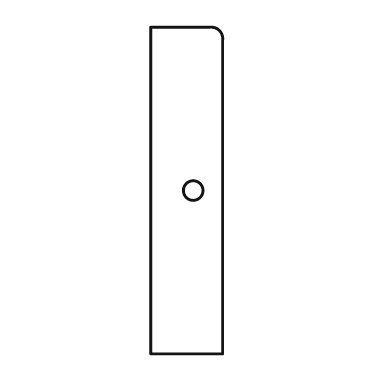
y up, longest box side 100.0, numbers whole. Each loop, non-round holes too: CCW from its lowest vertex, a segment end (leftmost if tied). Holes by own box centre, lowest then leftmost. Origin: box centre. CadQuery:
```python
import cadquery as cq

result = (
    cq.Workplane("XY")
    .moveTo(-11.0, -50.0)
    .lineTo(11.0, -50.0)
    .lineTo(11.0, 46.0)
    .threePointArc((10.0, 49.0), (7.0, 50.0))
    .lineTo(-11.0, 50.0)
    .close()
    .moveTo(2.0, 0.0)
    .circle(3.0)
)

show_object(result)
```